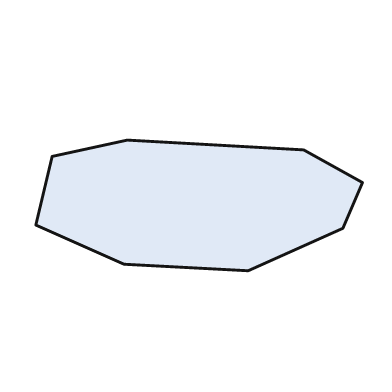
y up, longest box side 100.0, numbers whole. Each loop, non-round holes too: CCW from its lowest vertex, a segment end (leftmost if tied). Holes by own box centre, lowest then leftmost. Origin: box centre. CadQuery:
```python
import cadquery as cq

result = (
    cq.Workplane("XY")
    .moveTo(15.0, -20.0)
    .lineTo(44.0, -7.0)
    .lineTo(50.0, 7.0)
    .lineTo(32.0, 17.0)
    .lineTo(-22.0, 20.0)
    .lineTo(-45.0, 15.0)
    .lineTo(-50.0, -6.0)
    .lineTo(-23.0, -18.0)
    .close()
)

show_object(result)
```